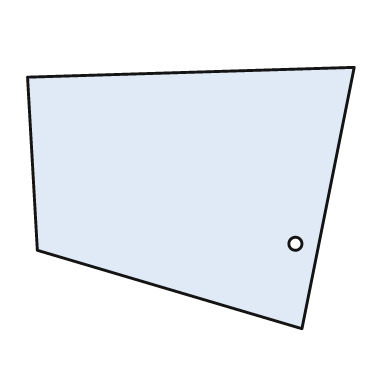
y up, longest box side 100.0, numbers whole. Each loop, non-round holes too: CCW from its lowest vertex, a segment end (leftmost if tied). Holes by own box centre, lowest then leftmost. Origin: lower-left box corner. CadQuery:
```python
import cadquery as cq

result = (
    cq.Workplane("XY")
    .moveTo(84.0, 0.0)
    .lineTo(100.0, 80.0)
    .lineTo(0.0, 77.0)
    .lineTo(3.0, 24.0)
    .close()
    .moveTo(82.0, 26.0)
    .circle(2.0)
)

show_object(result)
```